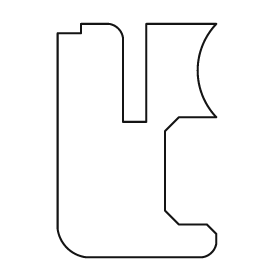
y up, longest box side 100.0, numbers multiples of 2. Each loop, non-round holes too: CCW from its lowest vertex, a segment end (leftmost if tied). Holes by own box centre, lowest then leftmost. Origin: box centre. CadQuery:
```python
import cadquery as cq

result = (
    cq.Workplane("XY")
    .moveTo(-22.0, -50.0)
    .lineTo(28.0, -50.0)
    .threePointArc((32.0, -48.0), (34.0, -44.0))
    .lineTo(34.0, -40.0)
    .lineTo(30.0, -36.0)
    .lineTo(18.0, -36.0)
    .lineTo(12.0, -30.0)
    .lineTo(12.0, 4.0)
    .lineTo(18.0, 10.0)
    .lineTo(34.0, 10.0)
    .threePointArc((26.0, 30.0), (34.0, 50.0))
    .lineTo(4.0, 50.0)
    .lineTo(4.0, 8.0)
    .lineTo(-6.0, 8.0)
    .lineTo(-6.0, 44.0)
    .threePointArc((-8.0, 48.0), (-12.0, 50.0))
    .lineTo(-24.0, 50.0)
    .lineTo(-24.0, 46.0)
    .lineTo(-34.0, 46.0)
    .lineTo(-34.0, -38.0)
    .threePointArc((-30.0, -46.0), (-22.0, -50.0))
    .close()
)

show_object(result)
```